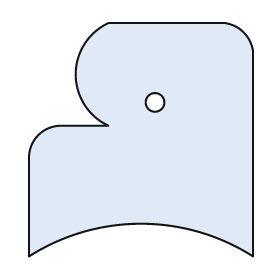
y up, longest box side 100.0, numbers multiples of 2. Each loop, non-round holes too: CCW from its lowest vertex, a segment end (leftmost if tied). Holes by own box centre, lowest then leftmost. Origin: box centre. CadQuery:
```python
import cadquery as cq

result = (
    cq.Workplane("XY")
    .moveTo(-48.0, -50.0)
    .threePointArc((0.0, -36.0), (48.0, -50.0))
    .lineTo(48.0, 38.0)
    .threePointArc((44.0, 46.0), (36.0, 50.0))
    .lineTo(-14.0, 50.0)
    .threePointArc((-28.0, 28.0), (-14.0, 6.0))
    .lineTo(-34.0, 6.0)
    .threePointArc((-44.0, 2.0), (-48.0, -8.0))
    .close()
    .moveTo(6.0, 16.0)
    .circle(4.0)
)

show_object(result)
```